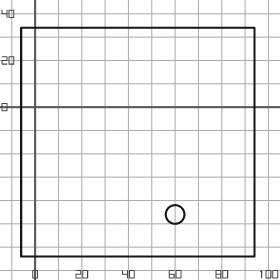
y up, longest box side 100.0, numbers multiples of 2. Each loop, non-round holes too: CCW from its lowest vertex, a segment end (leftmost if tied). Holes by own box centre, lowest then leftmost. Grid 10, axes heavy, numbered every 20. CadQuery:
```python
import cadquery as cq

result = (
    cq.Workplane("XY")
    .moveTo(-6.0, -64.0)
    .lineTo(94.0, -64.0)
    .lineTo(94.0, 34.0)
    .lineTo(-6.0, 34.0)
    .close()
    .moveTo(60.0, -46.0)
    .circle(4.0)
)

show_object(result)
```